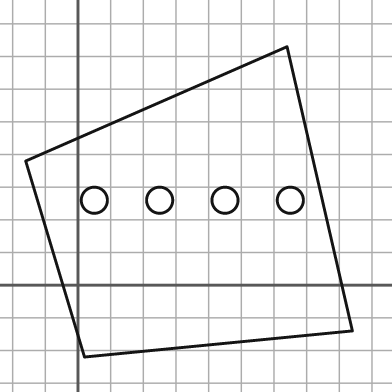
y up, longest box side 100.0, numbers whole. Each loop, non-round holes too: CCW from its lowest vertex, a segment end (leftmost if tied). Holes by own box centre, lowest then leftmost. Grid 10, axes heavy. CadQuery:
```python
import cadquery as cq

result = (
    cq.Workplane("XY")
    .moveTo(2.0, -22.0)
    .lineTo(84.0, -14.0)
    .lineTo(64.0, 73.0)
    .lineTo(-16.0, 38.0)
    .close()
    .moveTo(5.0, 26.0)
    .circle(4.0)
    .moveTo(25.0, 26.0)
    .circle(4.0)
    .moveTo(45.0, 26.0)
    .circle(4.0)
    .moveTo(65.0, 26.0)
    .circle(4.0)
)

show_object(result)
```